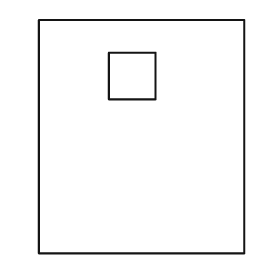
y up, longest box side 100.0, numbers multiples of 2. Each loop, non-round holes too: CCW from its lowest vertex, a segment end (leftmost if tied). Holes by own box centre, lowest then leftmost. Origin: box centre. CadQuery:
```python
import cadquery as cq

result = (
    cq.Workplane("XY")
    .moveTo(-44.0, -50.0)
    .lineTo(44.0, -50.0)
    .lineTo(44.0, 50.0)
    .lineTo(-44.0, 50.0)
    .close()
    .moveTo(-14.0, 16.0)
    .lineTo(6.0, 16.0)
    .lineTo(6.0, 36.0)
    .lineTo(-14.0, 36.0)
    .close()
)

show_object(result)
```